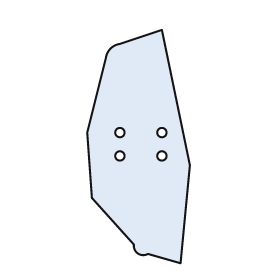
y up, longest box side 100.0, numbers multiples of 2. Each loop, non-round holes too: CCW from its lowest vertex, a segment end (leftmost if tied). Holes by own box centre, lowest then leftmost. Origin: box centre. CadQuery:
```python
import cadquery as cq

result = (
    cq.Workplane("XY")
    .moveTo(18.0, -50.0)
    .lineTo(22.0, -8.0)
    .lineTo(10.0, 50.0)
    .lineTo(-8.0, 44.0)
    .threePointArc((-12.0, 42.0), (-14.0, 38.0))
    .lineTo(-22.0, 6.0)
    .lineTo(-20.0, -22.0)
    .lineTo(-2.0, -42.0)
    .threePointArc((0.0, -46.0), (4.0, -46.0))
    .close()
    .moveTo(-8.0, -4.0)
    .circle(2.0)
    .moveTo(10.0, -4.0)
    .circle(2.0)
    .moveTo(-8.0, 6.0)
    .circle(2.0)
    .moveTo(10.0, 6.0)
    .circle(2.0)
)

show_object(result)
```